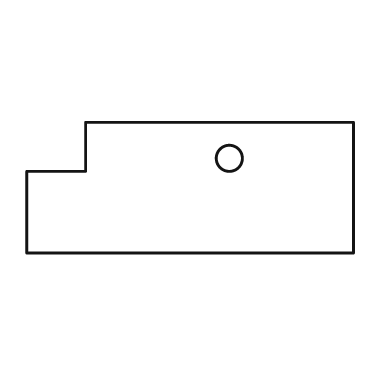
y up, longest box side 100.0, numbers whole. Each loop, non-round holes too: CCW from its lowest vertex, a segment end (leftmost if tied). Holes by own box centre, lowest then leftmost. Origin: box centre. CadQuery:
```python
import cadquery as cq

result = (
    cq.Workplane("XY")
    .moveTo(-50.0, -20.0)
    .lineTo(50.0, -20.0)
    .lineTo(50.0, 20.0)
    .lineTo(-32.0, 20.0)
    .lineTo(-32.0, 5.0)
    .lineTo(-50.0, 5.0)
    .close()
    .moveTo(12.0, 9.0)
    .circle(4.0)
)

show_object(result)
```